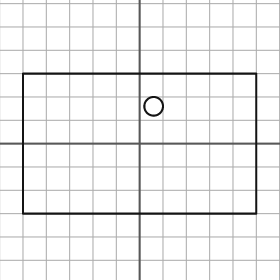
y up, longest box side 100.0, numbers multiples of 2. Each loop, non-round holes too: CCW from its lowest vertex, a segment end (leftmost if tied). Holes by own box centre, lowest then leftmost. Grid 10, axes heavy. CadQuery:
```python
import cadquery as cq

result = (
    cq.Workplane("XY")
    .moveTo(-50.0, -30.0)
    .lineTo(50.0, -30.0)
    .lineTo(50.0, 30.0)
    .lineTo(-50.0, 30.0)
    .close()
    .moveTo(6.0, 16.0)
    .circle(4.0)
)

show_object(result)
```